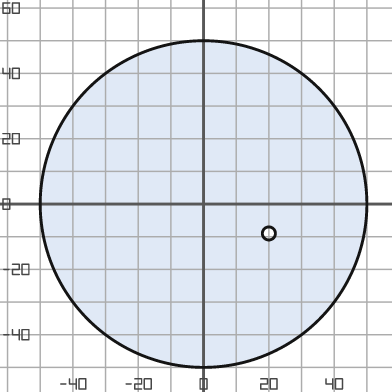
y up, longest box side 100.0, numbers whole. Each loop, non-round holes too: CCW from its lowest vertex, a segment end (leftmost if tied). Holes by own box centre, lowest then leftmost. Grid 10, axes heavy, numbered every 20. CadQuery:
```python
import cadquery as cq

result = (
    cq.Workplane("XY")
    .moveTo(0.0, 0.0)
    .circle(50.0)
    .moveTo(20.0, -9.0)
    .circle(2.0)
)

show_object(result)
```